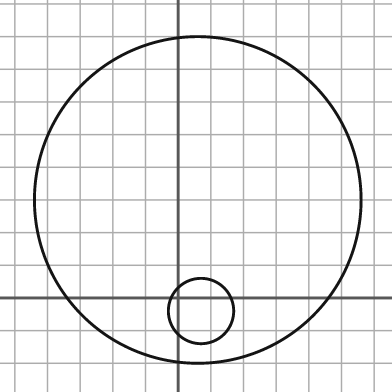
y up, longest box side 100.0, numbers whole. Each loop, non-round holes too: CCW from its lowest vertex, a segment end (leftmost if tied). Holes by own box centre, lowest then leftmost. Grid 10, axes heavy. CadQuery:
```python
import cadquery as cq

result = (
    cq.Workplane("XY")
    .moveTo(6.0, 30.0)
    .circle(50.0)
    .moveTo(7.0, -4.0)
    .circle(10.0)
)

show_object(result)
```